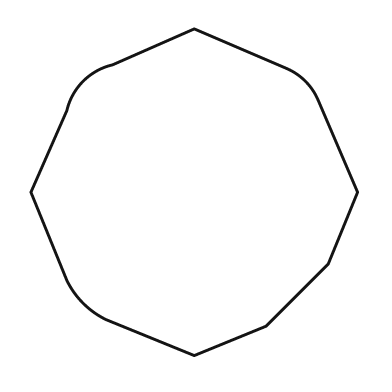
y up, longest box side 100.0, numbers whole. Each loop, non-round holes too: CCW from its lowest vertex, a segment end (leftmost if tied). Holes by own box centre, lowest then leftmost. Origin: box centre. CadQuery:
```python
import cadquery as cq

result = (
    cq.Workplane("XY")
    .moveTo(0.0, -50.0)
    .lineTo(22.0, -41.0)
    .lineTo(41.0, -22.0)
    .lineTo(50.0, 0.0)
    .lineTo(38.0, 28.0)
    .threePointArc((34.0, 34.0), (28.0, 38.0))
    .lineTo(0.0, 50.0)
    .lineTo(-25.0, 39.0)
    .threePointArc((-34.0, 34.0), (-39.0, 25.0))
    .lineTo(-50.0, 0.0)
    .lineTo(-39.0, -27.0)
    .threePointArc((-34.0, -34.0), (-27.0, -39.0))
    .close()
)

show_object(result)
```